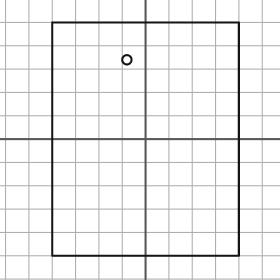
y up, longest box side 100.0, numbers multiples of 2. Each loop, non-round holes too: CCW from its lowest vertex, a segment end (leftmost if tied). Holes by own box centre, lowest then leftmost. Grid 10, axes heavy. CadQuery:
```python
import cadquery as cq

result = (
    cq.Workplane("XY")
    .moveTo(-40.0, -50.0)
    .lineTo(40.0, -50.0)
    .lineTo(40.0, 50.0)
    .lineTo(-40.0, 50.0)
    .close()
    .moveTo(-8.0, 34.0)
    .circle(2.0)
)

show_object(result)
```